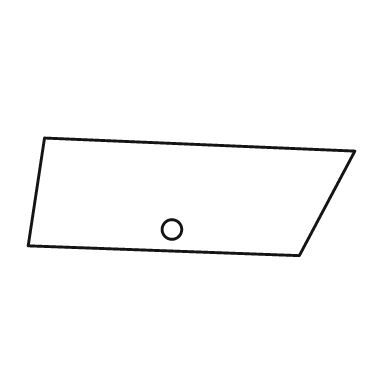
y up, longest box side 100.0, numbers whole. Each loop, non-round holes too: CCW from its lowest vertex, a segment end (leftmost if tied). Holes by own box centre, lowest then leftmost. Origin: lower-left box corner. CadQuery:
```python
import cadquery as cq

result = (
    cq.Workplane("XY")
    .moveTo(83.0, 0.0)
    .lineTo(100.0, 32.0)
    .lineTo(5.0, 36.0)
    .lineTo(0.0, 3.0)
    .close()
    .moveTo(44.0, 8.0)
    .circle(3.0)
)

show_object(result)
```